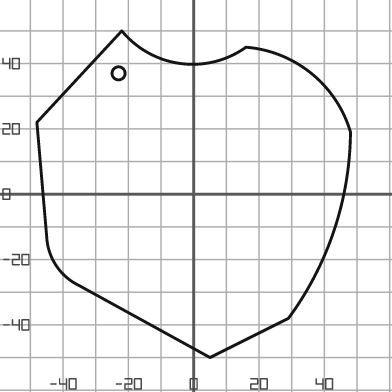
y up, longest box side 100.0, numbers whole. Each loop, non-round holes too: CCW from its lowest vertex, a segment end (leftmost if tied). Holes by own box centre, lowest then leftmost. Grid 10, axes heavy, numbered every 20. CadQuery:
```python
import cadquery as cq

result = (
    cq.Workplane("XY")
    .moveTo(5.0, -50.0)
    .lineTo(29.0, -38.0)
    .threePointArc((43.0, -11.0), (48.0, 19.0))
    .threePointArc((36.0, 37.0), (16.0, 45.0))
    .threePointArc((-4.0, 40.0), (-22.0, 50.0))
    .lineTo(-48.0, 22.0)
    .lineTo(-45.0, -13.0)
    .threePointArc((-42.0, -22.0), (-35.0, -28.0))
    .close()
    .moveTo(-23.0, 37.0)
    .circle(2.0)
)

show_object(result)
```